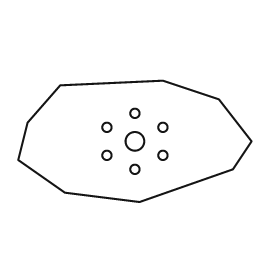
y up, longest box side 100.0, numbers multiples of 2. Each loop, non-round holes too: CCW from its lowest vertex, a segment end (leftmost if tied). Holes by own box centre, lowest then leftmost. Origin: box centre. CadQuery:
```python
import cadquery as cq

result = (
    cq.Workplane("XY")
    .moveTo(2.0, -26.0)
    .lineTo(42.0, -12.0)
    .lineTo(50.0, 0.0)
    .lineTo(36.0, 18.0)
    .lineTo(12.0, 26.0)
    .lineTo(-32.0, 24.0)
    .lineTo(-46.0, 8.0)
    .lineTo(-50.0, -8.0)
    .lineTo(-30.0, -22.0)
    .close()
    .moveTo(0.0, -12.0)
    .circle(2.0)
    .moveTo(-12.0, -6.0)
    .circle(2.0)
    .moveTo(12.0, -6.0)
    .circle(2.0)
    .moveTo(0.0, 0.0)
    .circle(4.0)
    .moveTo(-12.0, 6.0)
    .circle(2.0)
    .moveTo(12.0, 6.0)
    .circle(2.0)
    .moveTo(0.0, 12.0)
    .circle(2.0)
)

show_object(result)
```